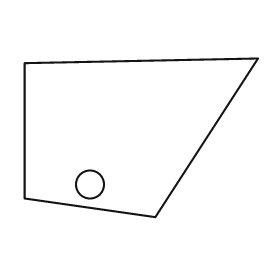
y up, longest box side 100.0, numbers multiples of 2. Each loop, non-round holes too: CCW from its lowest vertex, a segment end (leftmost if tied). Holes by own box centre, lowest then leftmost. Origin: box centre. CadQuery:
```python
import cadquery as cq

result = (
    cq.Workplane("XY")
    .moveTo(6.0, -34.0)
    .lineTo(50.0, 34.0)
    .lineTo(-50.0, 32.0)
    .lineTo(-50.0, -26.0)
    .close()
    .moveTo(-22.0, -20.0)
    .circle(6.0)
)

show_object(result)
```